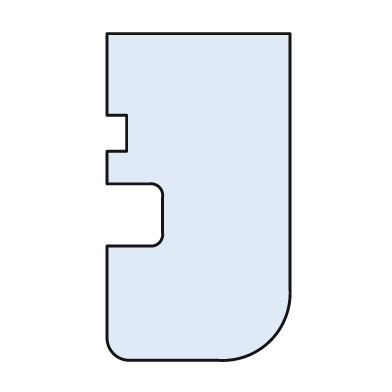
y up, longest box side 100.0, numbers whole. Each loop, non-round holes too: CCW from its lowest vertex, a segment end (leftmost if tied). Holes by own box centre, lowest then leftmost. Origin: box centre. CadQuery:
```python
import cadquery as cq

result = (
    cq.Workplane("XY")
    .moveTo(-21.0, -50.0)
    .lineTo(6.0, -50.0)
    .threePointArc((22.0, -44.0), (28.0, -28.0))
    .lineTo(28.0, 50.0)
    .lineTo(-28.0, 50.0)
    .lineTo(-28.0, 25.0)
    .lineTo(-22.0, 25.0)
    .lineTo(-22.0, 14.0)
    .lineTo(-28.0, 14.0)
    .lineTo(-28.0, 4.0)
    .lineTo(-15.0, 4.0)
    .threePointArc((-12.0, 3.0), (-11.0, 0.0))
    .lineTo(-11.0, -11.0)
    .threePointArc((-12.0, -14.0), (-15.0, -15.0))
    .lineTo(-28.0, -15.0)
    .lineTo(-28.0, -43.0)
    .threePointArc((-26.0, -48.0), (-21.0, -50.0))
    .close()
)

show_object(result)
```